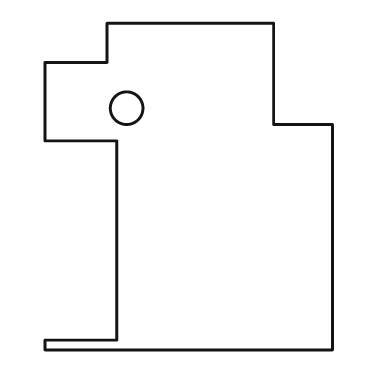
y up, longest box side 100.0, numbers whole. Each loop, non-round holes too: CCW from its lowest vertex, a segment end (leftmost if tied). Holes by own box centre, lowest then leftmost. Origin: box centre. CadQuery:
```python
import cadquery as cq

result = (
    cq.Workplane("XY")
    .moveTo(-44.0, -50.0)
    .lineTo(44.0, -50.0)
    .lineTo(44.0, 19.0)
    .lineTo(26.0, 19.0)
    .lineTo(26.0, 50.0)
    .lineTo(-25.0, 50.0)
    .lineTo(-25.0, 38.0)
    .lineTo(-44.0, 38.0)
    .lineTo(-44.0, 14.0)
    .lineTo(-22.0, 14.0)
    .lineTo(-22.0, -47.0)
    .lineTo(-44.0, -47.0)
    .close()
    .moveTo(-19.0, 24.0)
    .circle(5.0)
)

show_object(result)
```